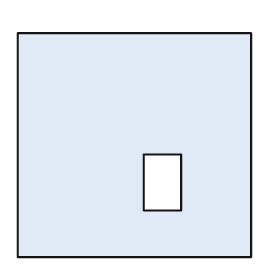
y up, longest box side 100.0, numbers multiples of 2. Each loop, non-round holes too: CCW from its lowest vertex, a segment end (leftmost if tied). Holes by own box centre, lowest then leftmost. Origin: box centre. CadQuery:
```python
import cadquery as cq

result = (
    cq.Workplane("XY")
    .moveTo(-50.0, -48.0)
    .lineTo(50.0, -48.0)
    .lineTo(50.0, 48.0)
    .lineTo(-50.0, 48.0)
    .close()
    .moveTo(4.0, -28.0)
    .lineTo(20.0, -28.0)
    .lineTo(20.0, -4.0)
    .lineTo(4.0, -4.0)
    .close()
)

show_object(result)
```